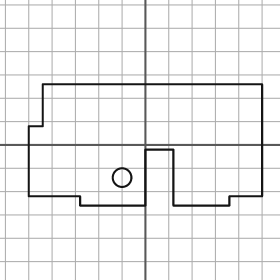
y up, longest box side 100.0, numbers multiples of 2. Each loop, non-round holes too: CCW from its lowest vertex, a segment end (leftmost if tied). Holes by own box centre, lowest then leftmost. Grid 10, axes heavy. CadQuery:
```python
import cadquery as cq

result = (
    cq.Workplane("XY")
    .moveTo(-28.0, -26.0)
    .lineTo(0.0, -26.0)
    .lineTo(0.0, -2.0)
    .lineTo(12.0, -2.0)
    .lineTo(12.0, -26.0)
    .lineTo(36.0, -26.0)
    .lineTo(36.0, -22.0)
    .lineTo(50.0, -22.0)
    .lineTo(50.0, 26.0)
    .lineTo(-44.0, 26.0)
    .lineTo(-44.0, 8.0)
    .lineTo(-50.0, 8.0)
    .lineTo(-50.0, -22.0)
    .lineTo(-28.0, -22.0)
    .close()
    .moveTo(-10.0, -14.0)
    .circle(4.0)
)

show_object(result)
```